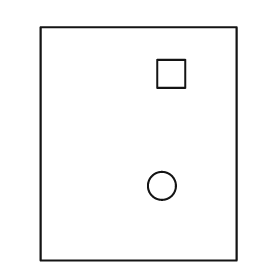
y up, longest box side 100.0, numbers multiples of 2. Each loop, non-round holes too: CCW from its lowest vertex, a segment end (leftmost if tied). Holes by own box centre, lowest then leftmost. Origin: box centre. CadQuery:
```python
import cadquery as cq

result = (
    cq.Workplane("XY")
    .moveTo(-42.0, -50.0)
    .lineTo(42.0, -50.0)
    .lineTo(42.0, 50.0)
    .lineTo(-42.0, 50.0)
    .close()
    .moveTo(10.0, -18.0)
    .circle(6.0)
    .moveTo(8.0, 24.0)
    .lineTo(20.0, 24.0)
    .lineTo(20.0, 36.0)
    .lineTo(8.0, 36.0)
    .close()
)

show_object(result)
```